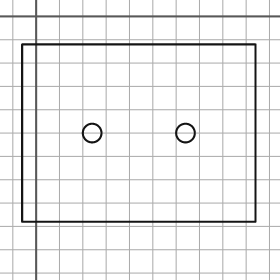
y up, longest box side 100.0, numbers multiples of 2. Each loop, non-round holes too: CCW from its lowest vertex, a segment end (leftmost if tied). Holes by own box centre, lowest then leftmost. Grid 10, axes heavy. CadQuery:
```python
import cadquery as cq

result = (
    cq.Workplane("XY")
    .moveTo(-6.0, -88.0)
    .lineTo(94.0, -88.0)
    .lineTo(94.0, -12.0)
    .lineTo(-6.0, -12.0)
    .close()
    .moveTo(24.0, -50.0)
    .circle(4.0)
    .moveTo(64.0, -50.0)
    .circle(4.0)
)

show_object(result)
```